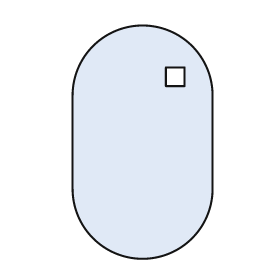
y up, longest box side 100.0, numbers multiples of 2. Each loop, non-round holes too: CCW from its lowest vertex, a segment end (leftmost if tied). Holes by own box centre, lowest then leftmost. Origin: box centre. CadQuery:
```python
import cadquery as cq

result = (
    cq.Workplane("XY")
    .moveTo(-30.0, -20.0)
    .threePointArc((0.0, -50.0), (30.0, -20.0))
    .lineTo(30.0, 20.0)
    .threePointArc((0.0, 50.0), (-30.0, 20.0))
    .close()
    .moveTo(10.0, 24.0)
    .lineTo(18.0, 24.0)
    .lineTo(18.0, 32.0)
    .lineTo(10.0, 32.0)
    .close()
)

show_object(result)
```